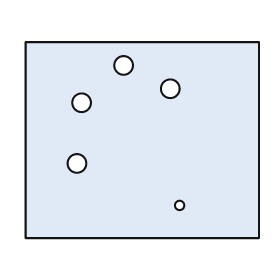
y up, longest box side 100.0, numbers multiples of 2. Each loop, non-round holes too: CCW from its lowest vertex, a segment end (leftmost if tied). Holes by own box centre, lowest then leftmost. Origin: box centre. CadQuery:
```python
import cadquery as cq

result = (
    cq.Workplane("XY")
    .moveTo(-50.0, -42.0)
    .lineTo(50.0, -42.0)
    .lineTo(50.0, 42.0)
    .lineTo(-50.0, 42.0)
    .close()
    .moveTo(16.0, -28.0)
    .circle(2.0)
    .moveTo(-28.0, -10.0)
    .circle(4.0)
    .moveTo(-26.0, 16.0)
    .circle(4.0)
    .moveTo(12.0, 22.0)
    .circle(4.0)
    .moveTo(-8.0, 32.0)
    .circle(4.0)
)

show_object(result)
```